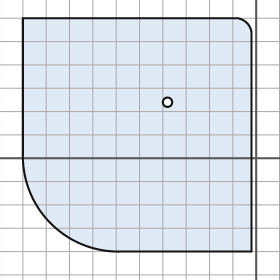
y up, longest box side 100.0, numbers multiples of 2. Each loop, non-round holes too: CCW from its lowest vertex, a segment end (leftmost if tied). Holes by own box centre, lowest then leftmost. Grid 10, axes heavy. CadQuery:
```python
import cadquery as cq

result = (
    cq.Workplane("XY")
    .moveTo(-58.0, -40.0)
    .lineTo(-2.0, -40.0)
    .lineTo(-2.0, 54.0)
    .threePointArc((-4.0, 58.0), (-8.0, 60.0))
    .lineTo(-100.0, 60.0)
    .lineTo(-100.0, 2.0)
    .threePointArc((-88.0, -28.0), (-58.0, -40.0))
    .close()
    .moveTo(-38.0, 24.0)
    .circle(2.0)
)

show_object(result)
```